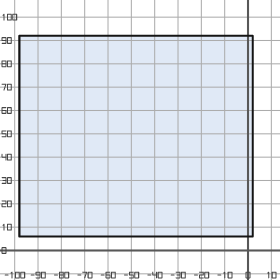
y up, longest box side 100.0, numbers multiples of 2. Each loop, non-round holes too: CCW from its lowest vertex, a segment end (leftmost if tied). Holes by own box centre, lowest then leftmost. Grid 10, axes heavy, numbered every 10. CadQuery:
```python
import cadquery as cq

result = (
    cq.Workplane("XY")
    .moveTo(-98.0, 6.0)
    .lineTo(2.0, 6.0)
    .lineTo(2.0, 92.0)
    .lineTo(-98.0, 92.0)
    .close()
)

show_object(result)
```